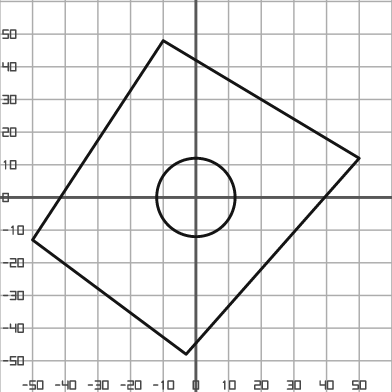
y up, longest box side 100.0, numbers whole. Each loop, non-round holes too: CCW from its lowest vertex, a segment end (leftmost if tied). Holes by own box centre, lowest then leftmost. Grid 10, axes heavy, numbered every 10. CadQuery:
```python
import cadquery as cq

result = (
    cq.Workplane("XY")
    .moveTo(-3.0, -48.0)
    .lineTo(50.0, 12.0)
    .lineTo(-10.0, 48.0)
    .lineTo(-50.0, -13.0)
    .close()
    .moveTo(0.0, 0.0)
    .circle(12.0)
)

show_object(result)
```